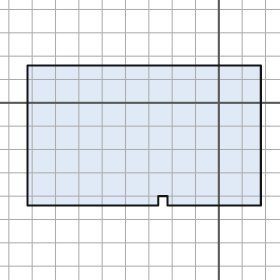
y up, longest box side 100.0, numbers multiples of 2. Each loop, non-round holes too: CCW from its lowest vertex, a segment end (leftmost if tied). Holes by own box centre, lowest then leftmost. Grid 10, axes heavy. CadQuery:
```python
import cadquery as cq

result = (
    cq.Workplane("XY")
    .moveTo(-82.0, -44.0)
    .lineTo(-26.0, -44.0)
    .lineTo(-26.0, -40.0)
    .lineTo(-22.0, -40.0)
    .lineTo(-22.0, -44.0)
    .lineTo(18.0, -44.0)
    .lineTo(18.0, 16.0)
    .lineTo(-82.0, 16.0)
    .close()
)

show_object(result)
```